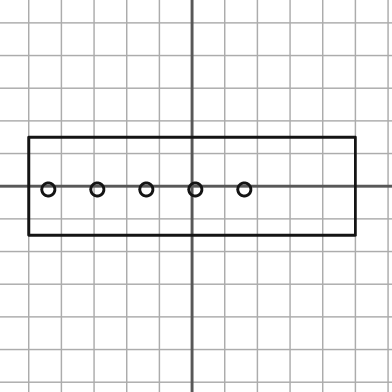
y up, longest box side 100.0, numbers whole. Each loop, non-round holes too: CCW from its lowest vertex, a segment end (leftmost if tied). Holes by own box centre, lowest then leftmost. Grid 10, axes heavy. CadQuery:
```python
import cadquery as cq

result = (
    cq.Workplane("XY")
    .moveTo(-50.0, -15.0)
    .lineTo(50.0, -15.0)
    .lineTo(50.0, 15.0)
    .lineTo(-50.0, 15.0)
    .close()
    .moveTo(-44.0, -1.0)
    .circle(2.0)
    .moveTo(-29.0, -1.0)
    .circle(2.0)
    .moveTo(-14.0, -1.0)
    .circle(2.0)
    .moveTo(1.0, -1.0)
    .circle(2.0)
    .moveTo(16.0, -1.0)
    .circle(2.0)
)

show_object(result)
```